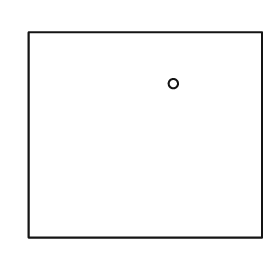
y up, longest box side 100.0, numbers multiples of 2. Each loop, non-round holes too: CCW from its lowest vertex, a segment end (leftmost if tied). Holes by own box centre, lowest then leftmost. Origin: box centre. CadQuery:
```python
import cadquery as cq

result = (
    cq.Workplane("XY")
    .moveTo(-50.0, -44.0)
    .lineTo(50.0, -44.0)
    .lineTo(50.0, 44.0)
    .lineTo(-50.0, 44.0)
    .close()
    .moveTo(12.0, 22.0)
    .circle(2.0)
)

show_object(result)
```